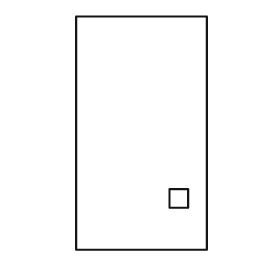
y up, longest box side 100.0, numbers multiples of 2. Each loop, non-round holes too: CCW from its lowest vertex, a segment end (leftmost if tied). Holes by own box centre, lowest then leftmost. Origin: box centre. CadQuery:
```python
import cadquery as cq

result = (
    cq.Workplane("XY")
    .moveTo(-28.0, -50.0)
    .lineTo(28.0, -50.0)
    .lineTo(28.0, 50.0)
    .lineTo(-28.0, 50.0)
    .close()
    .moveTo(12.0, -32.0)
    .lineTo(20.0, -32.0)
    .lineTo(20.0, -24.0)
    .lineTo(12.0, -24.0)
    .close()
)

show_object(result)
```